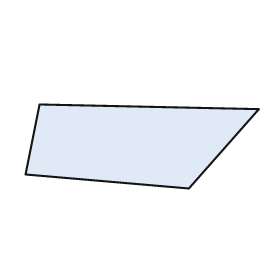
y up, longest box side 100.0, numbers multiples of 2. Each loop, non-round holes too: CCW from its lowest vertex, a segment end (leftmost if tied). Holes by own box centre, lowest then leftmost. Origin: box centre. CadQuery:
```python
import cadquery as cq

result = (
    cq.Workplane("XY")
    .moveTo(20.0, -18.0)
    .lineTo(50.0, 16.0)
    .lineTo(-44.0, 18.0)
    .lineTo(-50.0, -12.0)
    .close()
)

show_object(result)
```